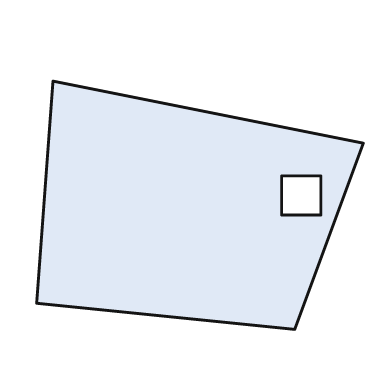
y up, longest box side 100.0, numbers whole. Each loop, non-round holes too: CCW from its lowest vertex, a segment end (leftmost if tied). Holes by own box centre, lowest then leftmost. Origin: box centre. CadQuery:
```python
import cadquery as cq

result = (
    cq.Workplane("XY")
    .moveTo(29.0, -38.0)
    .lineTo(50.0, 19.0)
    .lineTo(-45.0, 38.0)
    .lineTo(-50.0, -30.0)
    .close()
    .moveTo(25.0, -3.0)
    .lineTo(37.0, -3.0)
    .lineTo(37.0, 9.0)
    .lineTo(25.0, 9.0)
    .close()
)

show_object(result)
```